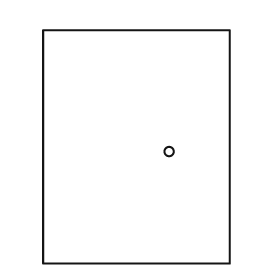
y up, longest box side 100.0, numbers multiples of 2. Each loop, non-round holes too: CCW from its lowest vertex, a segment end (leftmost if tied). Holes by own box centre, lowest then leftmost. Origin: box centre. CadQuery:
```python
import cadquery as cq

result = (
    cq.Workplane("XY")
    .moveTo(-40.0, -50.0)
    .lineTo(40.0, -50.0)
    .lineTo(40.0, 50.0)
    .lineTo(-40.0, 50.0)
    .close()
    .moveTo(14.0, -2.0)
    .circle(2.0)
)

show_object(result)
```